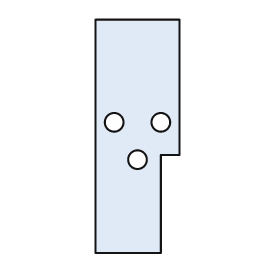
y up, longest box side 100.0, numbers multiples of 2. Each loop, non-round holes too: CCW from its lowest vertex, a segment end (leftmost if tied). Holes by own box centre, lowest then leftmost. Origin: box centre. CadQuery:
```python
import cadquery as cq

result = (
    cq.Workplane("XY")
    .moveTo(-18.0, -50.0)
    .lineTo(10.0, -50.0)
    .lineTo(10.0, -8.0)
    .lineTo(18.0, -8.0)
    .lineTo(18.0, 50.0)
    .lineTo(-18.0, 50.0)
    .close()
    .moveTo(0.0, -10.0)
    .circle(4.0)
    .moveTo(-10.0, 6.0)
    .circle(4.0)
    .moveTo(10.0, 6.0)
    .circle(4.0)
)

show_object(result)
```